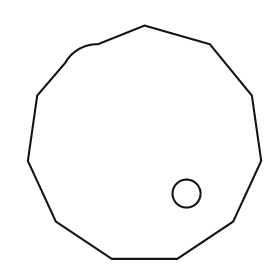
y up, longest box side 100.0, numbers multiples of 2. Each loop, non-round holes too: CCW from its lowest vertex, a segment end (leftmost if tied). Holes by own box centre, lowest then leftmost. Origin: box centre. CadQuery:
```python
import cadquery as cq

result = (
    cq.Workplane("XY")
    .moveTo(-14.0, -50.0)
    .lineTo(14.0, -50.0)
    .lineTo(38.0, -34.0)
    .lineTo(50.0, -8.0)
    .lineTo(46.0, 20.0)
    .lineTo(28.0, 42.0)
    .lineTo(0.0, 50.0)
    .lineTo(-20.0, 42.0)
    .threePointArc((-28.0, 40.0), (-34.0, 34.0))
    .lineTo(-46.0, 20.0)
    .lineTo(-50.0, -8.0)
    .lineTo(-38.0, -34.0)
    .close()
    .moveTo(18.0, -22.0)
    .circle(6.0)
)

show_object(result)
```